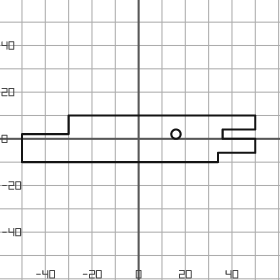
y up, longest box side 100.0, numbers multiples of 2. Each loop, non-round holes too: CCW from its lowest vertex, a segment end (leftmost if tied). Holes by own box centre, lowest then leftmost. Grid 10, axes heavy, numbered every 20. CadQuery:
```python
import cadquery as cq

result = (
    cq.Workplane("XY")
    .moveTo(-50.0, -10.0)
    .lineTo(34.0, -10.0)
    .lineTo(34.0, -6.0)
    .lineTo(50.0, -6.0)
    .lineTo(50.0, 0.0)
    .lineTo(36.0, 0.0)
    .lineTo(36.0, 4.0)
    .lineTo(50.0, 4.0)
    .lineTo(50.0, 10.0)
    .lineTo(-30.0, 10.0)
    .lineTo(-30.0, 2.0)
    .lineTo(-50.0, 2.0)
    .close()
    .moveTo(16.0, 2.0)
    .circle(2.0)
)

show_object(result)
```